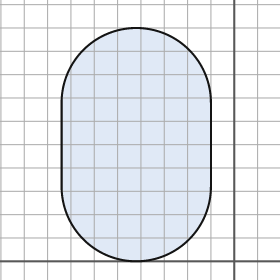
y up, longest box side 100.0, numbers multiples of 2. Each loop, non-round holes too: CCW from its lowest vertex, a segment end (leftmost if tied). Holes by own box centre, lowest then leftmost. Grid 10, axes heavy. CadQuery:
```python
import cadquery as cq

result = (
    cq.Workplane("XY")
    .moveTo(-74.0, 32.0)
    .threePointArc((-42.0, 0.0), (-10.0, 32.0))
    .lineTo(-10.0, 68.0)
    .threePointArc((-42.0, 100.0), (-74.0, 68.0))
    .close()
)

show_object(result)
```